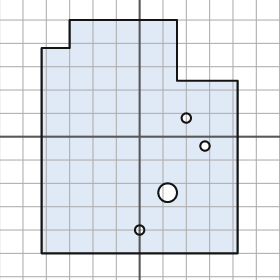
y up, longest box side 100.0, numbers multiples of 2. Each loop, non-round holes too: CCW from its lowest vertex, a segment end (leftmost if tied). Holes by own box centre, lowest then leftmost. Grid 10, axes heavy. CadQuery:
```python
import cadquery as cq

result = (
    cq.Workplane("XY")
    .moveTo(-42.0, -50.0)
    .lineTo(42.0, -50.0)
    .lineTo(42.0, 24.0)
    .lineTo(16.0, 24.0)
    .lineTo(16.0, 50.0)
    .lineTo(-30.0, 50.0)
    .lineTo(-30.0, 38.0)
    .lineTo(-42.0, 38.0)
    .close()
    .moveTo(0.0, -40.0)
    .circle(2.0)
    .moveTo(12.0, -24.0)
    .circle(4.0)
    .moveTo(28.0, -4.0)
    .circle(2.0)
    .moveTo(20.0, 8.0)
    .circle(2.0)
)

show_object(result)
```